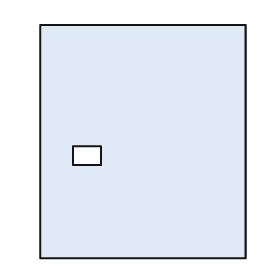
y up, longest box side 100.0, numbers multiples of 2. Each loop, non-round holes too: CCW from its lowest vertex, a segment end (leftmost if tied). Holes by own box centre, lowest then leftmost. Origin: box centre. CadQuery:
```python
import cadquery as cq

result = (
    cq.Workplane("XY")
    .moveTo(-44.0, -50.0)
    .lineTo(44.0, -50.0)
    .lineTo(44.0, 50.0)
    .lineTo(-44.0, 50.0)
    .close()
    .moveTo(-30.0, -10.0)
    .lineTo(-18.0, -10.0)
    .lineTo(-18.0, -2.0)
    .lineTo(-30.0, -2.0)
    .close()
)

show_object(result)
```